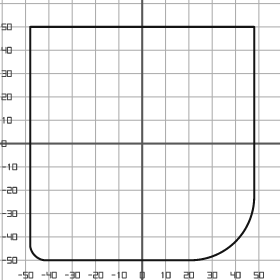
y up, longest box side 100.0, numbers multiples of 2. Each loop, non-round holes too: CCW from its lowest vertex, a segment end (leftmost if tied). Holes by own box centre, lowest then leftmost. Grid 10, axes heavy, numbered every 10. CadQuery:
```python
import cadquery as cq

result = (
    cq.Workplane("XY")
    .moveTo(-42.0, -50.0)
    .lineTo(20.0, -50.0)
    .threePointArc((40.0, -42.0), (48.0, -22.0))
    .lineTo(48.0, 50.0)
    .lineTo(-48.0, 50.0)
    .lineTo(-48.0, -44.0)
    .threePointArc((-46.0, -48.0), (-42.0, -50.0))
    .close()
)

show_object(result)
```